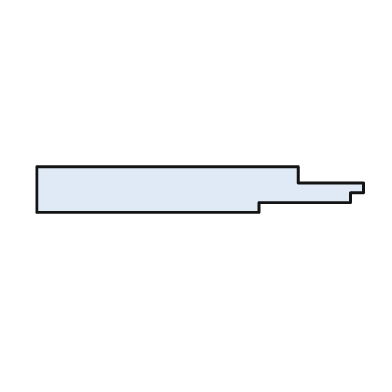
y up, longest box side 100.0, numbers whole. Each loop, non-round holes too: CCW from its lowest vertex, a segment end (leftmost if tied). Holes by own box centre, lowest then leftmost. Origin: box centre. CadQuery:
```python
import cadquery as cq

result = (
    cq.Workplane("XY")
    .moveTo(-50.0, -7.0)
    .lineTo(18.0, -7.0)
    .lineTo(18.0, -4.0)
    .lineTo(46.0, -4.0)
    .lineTo(46.0, -1.0)
    .lineTo(50.0, -1.0)
    .lineTo(50.0, 2.0)
    .lineTo(30.0, 2.0)
    .lineTo(30.0, 7.0)
    .lineTo(-50.0, 7.0)
    .close()
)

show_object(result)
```